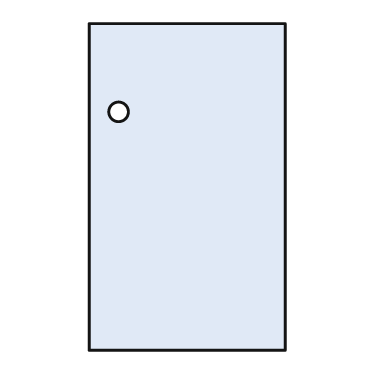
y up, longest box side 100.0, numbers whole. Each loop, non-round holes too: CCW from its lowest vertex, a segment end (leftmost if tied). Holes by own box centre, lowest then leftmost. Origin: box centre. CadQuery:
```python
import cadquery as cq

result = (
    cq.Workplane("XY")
    .moveTo(-30.0, -50.0)
    .lineTo(30.0, -50.0)
    .lineTo(30.0, 50.0)
    .lineTo(-30.0, 50.0)
    .close()
    .moveTo(-21.0, 23.0)
    .circle(3.0)
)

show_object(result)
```